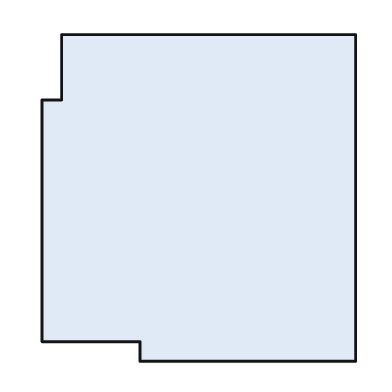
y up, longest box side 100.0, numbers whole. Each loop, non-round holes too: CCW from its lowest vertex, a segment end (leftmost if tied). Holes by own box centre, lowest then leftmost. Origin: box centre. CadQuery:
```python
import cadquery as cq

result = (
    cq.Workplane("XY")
    .moveTo(-18.0, -50.0)
    .lineTo(48.0, -50.0)
    .lineTo(48.0, 50.0)
    .lineTo(-42.0, 50.0)
    .lineTo(-42.0, 30.0)
    .lineTo(-48.0, 30.0)
    .lineTo(-48.0, -44.0)
    .lineTo(-18.0, -44.0)
    .close()
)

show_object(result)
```